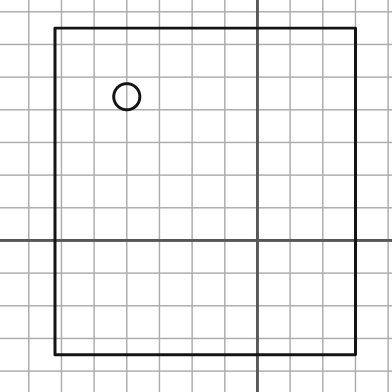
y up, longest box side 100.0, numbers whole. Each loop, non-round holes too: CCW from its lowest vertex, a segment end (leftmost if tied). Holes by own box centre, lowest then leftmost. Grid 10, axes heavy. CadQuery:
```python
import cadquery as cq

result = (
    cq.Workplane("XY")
    .moveTo(-62.0, -35.0)
    .lineTo(30.0, -35.0)
    .lineTo(30.0, 65.0)
    .lineTo(-62.0, 65.0)
    .close()
    .moveTo(-40.0, 44.0)
    .circle(4.0)
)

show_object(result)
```